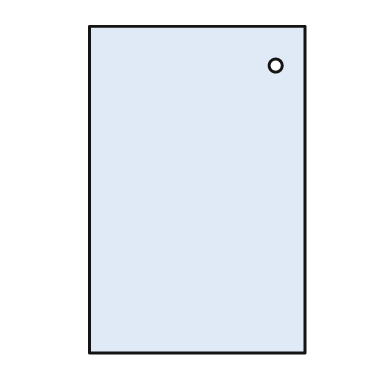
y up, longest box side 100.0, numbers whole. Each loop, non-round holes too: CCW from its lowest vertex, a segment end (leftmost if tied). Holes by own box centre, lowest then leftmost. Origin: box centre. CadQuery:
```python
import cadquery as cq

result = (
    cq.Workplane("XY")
    .moveTo(-33.0, -50.0)
    .lineTo(33.0, -50.0)
    .lineTo(33.0, 50.0)
    .lineTo(-33.0, 50.0)
    .close()
    .moveTo(24.0, 38.0)
    .circle(2.0)
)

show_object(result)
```